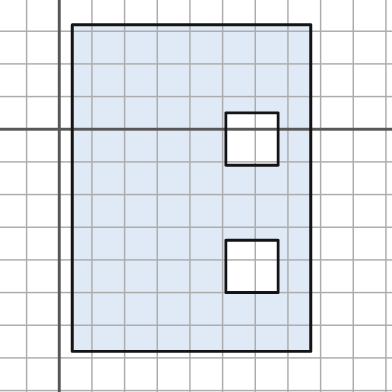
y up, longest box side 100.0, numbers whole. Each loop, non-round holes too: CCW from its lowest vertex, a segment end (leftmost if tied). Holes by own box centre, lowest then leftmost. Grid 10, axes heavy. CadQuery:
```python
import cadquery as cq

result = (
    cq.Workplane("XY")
    .moveTo(4.0, -68.0)
    .lineTo(77.0, -68.0)
    .lineTo(77.0, 32.0)
    .lineTo(4.0, 32.0)
    .close()
    .moveTo(51.0, -50.0)
    .lineTo(67.0, -50.0)
    .lineTo(67.0, -34.0)
    .lineTo(51.0, -34.0)
    .close()
    .moveTo(51.0, -11.0)
    .lineTo(67.0, -11.0)
    .lineTo(67.0, 5.0)
    .lineTo(51.0, 5.0)
    .close()
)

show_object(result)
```